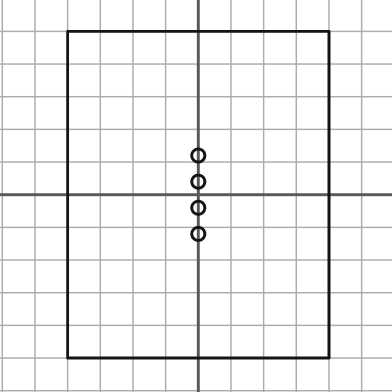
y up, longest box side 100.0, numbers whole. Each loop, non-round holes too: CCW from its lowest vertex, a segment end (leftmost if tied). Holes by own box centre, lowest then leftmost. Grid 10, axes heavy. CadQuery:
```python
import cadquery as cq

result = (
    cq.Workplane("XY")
    .moveTo(-40.0, -50.0)
    .lineTo(40.0, -50.0)
    .lineTo(40.0, 50.0)
    .lineTo(-40.0, 50.0)
    .close()
    .moveTo(0.0, -12.0)
    .circle(2.0)
    .moveTo(0.0, -4.0)
    .circle(2.0)
    .moveTo(0.0, 4.0)
    .circle(2.0)
    .moveTo(0.0, 12.0)
    .circle(2.0)
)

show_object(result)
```